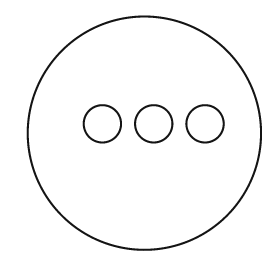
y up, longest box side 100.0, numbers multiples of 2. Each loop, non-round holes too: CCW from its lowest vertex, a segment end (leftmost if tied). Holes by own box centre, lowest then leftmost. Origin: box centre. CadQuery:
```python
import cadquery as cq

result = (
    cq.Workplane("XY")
    .moveTo(0.0, 0.0)
    .circle(50.0)
    .moveTo(-18.0, 4.0)
    .circle(8.0)
    .moveTo(4.0, 4.0)
    .circle(8.0)
    .moveTo(26.0, 4.0)
    .circle(8.0)
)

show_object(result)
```